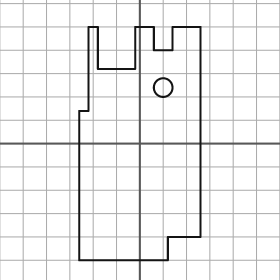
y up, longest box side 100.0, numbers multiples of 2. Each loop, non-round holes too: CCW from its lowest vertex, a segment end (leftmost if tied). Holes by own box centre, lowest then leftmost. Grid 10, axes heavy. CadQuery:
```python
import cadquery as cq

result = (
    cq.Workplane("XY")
    .moveTo(-26.0, -50.0)
    .lineTo(12.0, -50.0)
    .lineTo(12.0, -40.0)
    .lineTo(26.0, -40.0)
    .lineTo(26.0, 50.0)
    .lineTo(14.0, 50.0)
    .lineTo(14.0, 40.0)
    .lineTo(6.0, 40.0)
    .lineTo(6.0, 50.0)
    .lineTo(-2.0, 50.0)
    .lineTo(-2.0, 32.0)
    .lineTo(-18.0, 32.0)
    .lineTo(-18.0, 50.0)
    .lineTo(-22.0, 50.0)
    .lineTo(-22.0, 14.0)
    .lineTo(-26.0, 14.0)
    .close()
    .moveTo(10.0, 24.0)
    .circle(4.0)
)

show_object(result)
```